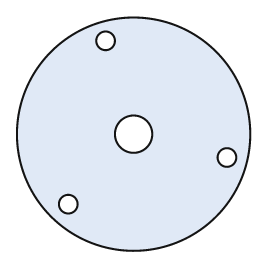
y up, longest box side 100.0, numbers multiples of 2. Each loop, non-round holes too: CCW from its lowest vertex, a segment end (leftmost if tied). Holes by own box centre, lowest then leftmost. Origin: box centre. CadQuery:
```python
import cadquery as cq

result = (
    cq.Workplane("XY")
    .moveTo(0.0, 0.0)
    .circle(50.0)
    .moveTo(-28.0, -30.0)
    .circle(4.0)
    .moveTo(40.0, -10.0)
    .circle(4.0)
    .moveTo(0.0, 0.0)
    .circle(8.0)
    .moveTo(-12.0, 40.0)
    .circle(4.0)
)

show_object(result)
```